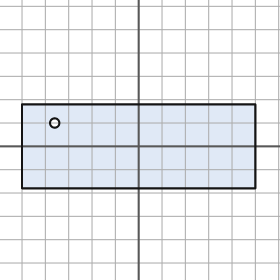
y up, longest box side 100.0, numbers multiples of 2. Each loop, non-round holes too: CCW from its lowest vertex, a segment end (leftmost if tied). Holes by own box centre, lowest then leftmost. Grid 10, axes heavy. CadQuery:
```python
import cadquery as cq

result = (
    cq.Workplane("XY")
    .moveTo(-50.0, -18.0)
    .lineTo(50.0, -18.0)
    .lineTo(50.0, 18.0)
    .lineTo(-50.0, 18.0)
    .close()
    .moveTo(-36.0, 10.0)
    .circle(2.0)
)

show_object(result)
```